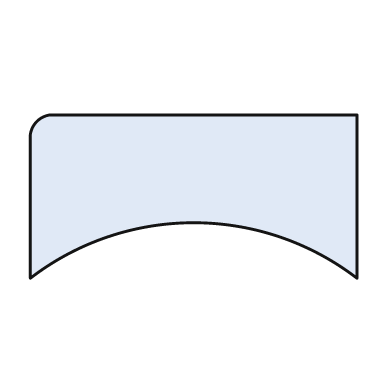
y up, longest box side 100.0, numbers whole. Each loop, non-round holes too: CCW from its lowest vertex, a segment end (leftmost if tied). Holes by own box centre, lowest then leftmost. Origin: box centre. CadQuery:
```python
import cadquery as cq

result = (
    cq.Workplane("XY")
    .moveTo(-50.0, -25.0)
    .threePointArc((0.0, -8.0), (50.0, -25.0))
    .lineTo(50.0, 25.0)
    .lineTo(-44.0, 25.0)
    .threePointArc((-48.0, 23.0), (-50.0, 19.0))
    .close()
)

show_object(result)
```